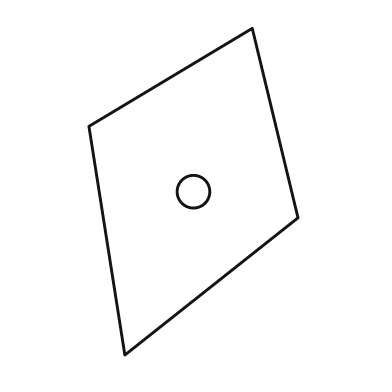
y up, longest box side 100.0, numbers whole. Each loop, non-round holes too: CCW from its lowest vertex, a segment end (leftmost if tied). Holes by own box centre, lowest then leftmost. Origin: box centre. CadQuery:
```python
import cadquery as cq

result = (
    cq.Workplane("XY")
    .moveTo(-21.0, -50.0)
    .lineTo(32.0, -8.0)
    .lineTo(18.0, 50.0)
    .lineTo(-32.0, 20.0)
    .close()
    .moveTo(0.0, 0.0)
    .circle(5.0)
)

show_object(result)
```